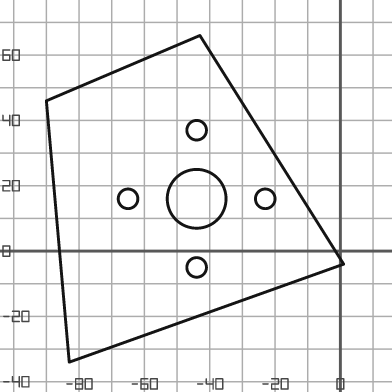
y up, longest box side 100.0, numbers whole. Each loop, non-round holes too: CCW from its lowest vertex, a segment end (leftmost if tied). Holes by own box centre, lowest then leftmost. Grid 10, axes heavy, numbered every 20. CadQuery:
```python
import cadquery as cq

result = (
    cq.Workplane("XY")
    .moveTo(-83.0, -34.0)
    .lineTo(1.0, -4.0)
    .lineTo(-43.0, 66.0)
    .lineTo(-90.0, 46.0)
    .close()
    .moveTo(-44.0, -5.0)
    .circle(3.0)
    .moveTo(-65.0, 16.0)
    .circle(3.0)
    .moveTo(-44.0, 16.0)
    .circle(9.0)
    .moveTo(-23.0, 16.0)
    .circle(3.0)
    .moveTo(-44.0, 37.0)
    .circle(3.0)
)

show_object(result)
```